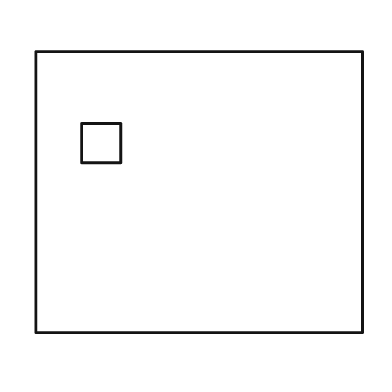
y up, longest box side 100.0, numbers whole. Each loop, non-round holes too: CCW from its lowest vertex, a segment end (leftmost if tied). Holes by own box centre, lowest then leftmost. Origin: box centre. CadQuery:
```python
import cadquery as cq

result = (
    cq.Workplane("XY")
    .moveTo(-50.0, -43.0)
    .lineTo(50.0, -43.0)
    .lineTo(50.0, 43.0)
    .lineTo(-50.0, 43.0)
    .close()
    .moveTo(-36.0, 9.0)
    .lineTo(-24.0, 9.0)
    .lineTo(-24.0, 21.0)
    .lineTo(-36.0, 21.0)
    .close()
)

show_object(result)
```